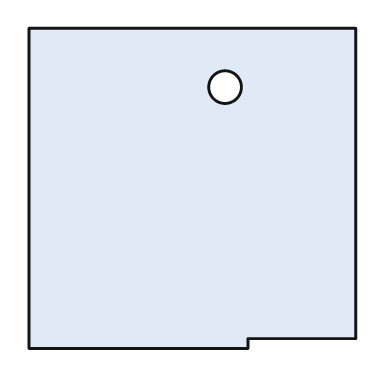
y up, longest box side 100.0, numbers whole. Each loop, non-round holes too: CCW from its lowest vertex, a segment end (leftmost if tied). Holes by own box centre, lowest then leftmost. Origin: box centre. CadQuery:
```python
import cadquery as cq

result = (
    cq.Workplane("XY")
    .moveTo(-50.0, -49.0)
    .lineTo(17.0, -49.0)
    .lineTo(17.0, -46.0)
    .lineTo(50.0, -46.0)
    .lineTo(50.0, 49.0)
    .lineTo(-50.0, 49.0)
    .close()
    .moveTo(10.0, 31.0)
    .circle(5.0)
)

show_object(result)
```